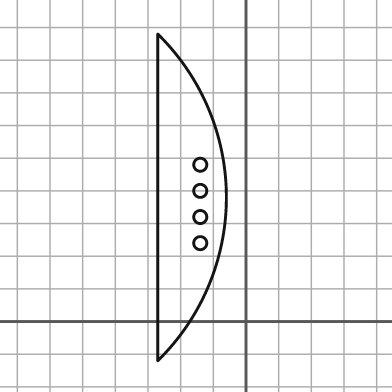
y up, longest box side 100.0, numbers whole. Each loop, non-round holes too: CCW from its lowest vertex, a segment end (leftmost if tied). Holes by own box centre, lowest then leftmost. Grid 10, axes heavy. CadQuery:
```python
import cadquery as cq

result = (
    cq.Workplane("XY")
    .moveTo(-27.0, -12.0)
    .threePointArc((-6.0, 38.0), (-27.0, 88.0))
    .close()
    .moveTo(-14.0, 24.0)
    .circle(2.0)
    .moveTo(-14.0, 32.0)
    .circle(2.0)
    .moveTo(-14.0, 40.0)
    .circle(2.0)
    .moveTo(-14.0, 48.0)
    .circle(2.0)
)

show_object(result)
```